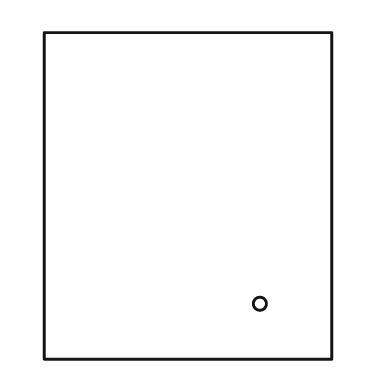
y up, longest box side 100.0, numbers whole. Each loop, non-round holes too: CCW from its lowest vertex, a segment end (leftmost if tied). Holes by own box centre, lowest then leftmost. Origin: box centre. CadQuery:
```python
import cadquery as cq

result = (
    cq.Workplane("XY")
    .moveTo(-44.0, -50.0)
    .lineTo(44.0, -50.0)
    .lineTo(44.0, 50.0)
    .lineTo(-44.0, 50.0)
    .close()
    .moveTo(22.0, -33.0)
    .circle(2.0)
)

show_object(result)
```